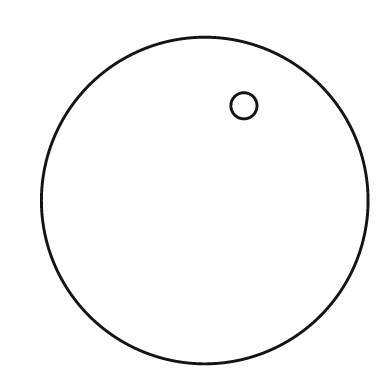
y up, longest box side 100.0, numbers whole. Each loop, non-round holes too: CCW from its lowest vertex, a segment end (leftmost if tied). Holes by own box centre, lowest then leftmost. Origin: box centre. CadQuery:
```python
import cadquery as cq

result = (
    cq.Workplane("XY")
    .moveTo(0.0, 0.0)
    .circle(50.0)
    .moveTo(12.0, 29.0)
    .circle(4.0)
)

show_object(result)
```